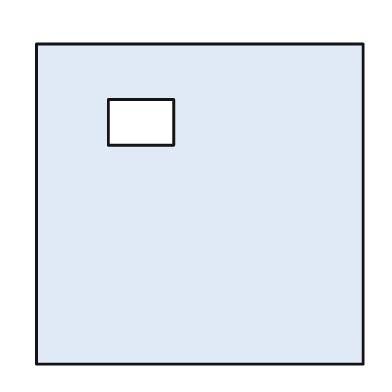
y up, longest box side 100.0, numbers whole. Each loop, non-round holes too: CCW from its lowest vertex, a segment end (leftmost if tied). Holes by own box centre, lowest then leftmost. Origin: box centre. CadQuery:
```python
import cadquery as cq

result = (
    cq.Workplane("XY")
    .moveTo(-50.0, -49.0)
    .lineTo(50.0, -49.0)
    .lineTo(50.0, 49.0)
    .lineTo(-50.0, 49.0)
    .close()
    .moveTo(-28.0, 18.0)
    .lineTo(-8.0, 18.0)
    .lineTo(-8.0, 32.0)
    .lineTo(-28.0, 32.0)
    .close()
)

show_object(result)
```